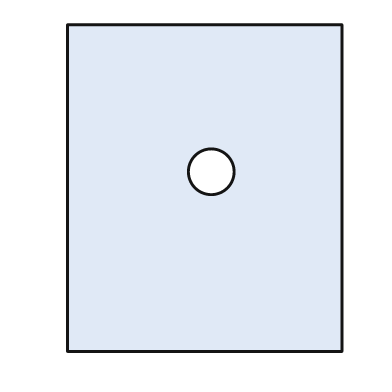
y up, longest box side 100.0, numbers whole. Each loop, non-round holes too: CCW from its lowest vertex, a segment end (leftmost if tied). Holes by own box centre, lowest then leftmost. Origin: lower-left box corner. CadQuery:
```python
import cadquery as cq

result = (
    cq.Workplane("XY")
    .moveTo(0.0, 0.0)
    .lineTo(84.0, 0.0)
    .lineTo(84.0, 100.0)
    .lineTo(0.0, 100.0)
    .close()
    .moveTo(44.0, 55.0)
    .circle(7.0)
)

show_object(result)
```